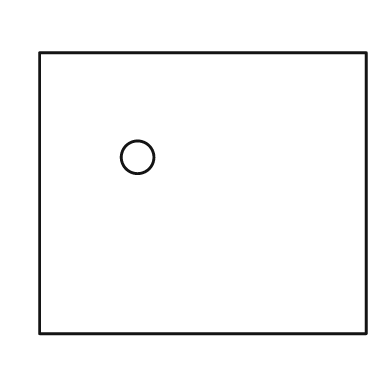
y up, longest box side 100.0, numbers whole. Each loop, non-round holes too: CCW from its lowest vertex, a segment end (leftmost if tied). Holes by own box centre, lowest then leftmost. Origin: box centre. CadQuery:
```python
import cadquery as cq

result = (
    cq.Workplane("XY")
    .moveTo(-50.0, -43.0)
    .lineTo(50.0, -43.0)
    .lineTo(50.0, 43.0)
    .lineTo(-50.0, 43.0)
    .close()
    .moveTo(-20.0, 11.0)
    .circle(5.0)
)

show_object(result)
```